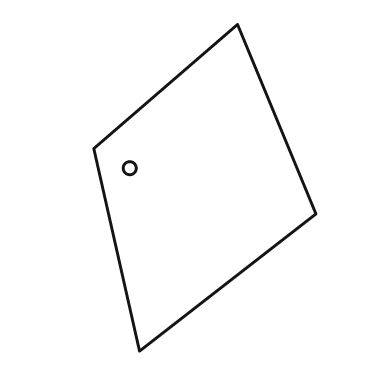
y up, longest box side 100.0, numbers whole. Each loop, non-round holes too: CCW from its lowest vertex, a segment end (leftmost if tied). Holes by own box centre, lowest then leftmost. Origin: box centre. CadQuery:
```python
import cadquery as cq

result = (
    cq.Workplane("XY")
    .moveTo(-20.0, -50.0)
    .lineTo(34.0, -8.0)
    .lineTo(10.0, 50.0)
    .lineTo(-34.0, 12.0)
    .close()
    .moveTo(-23.0, 6.0)
    .circle(2.0)
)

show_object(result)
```